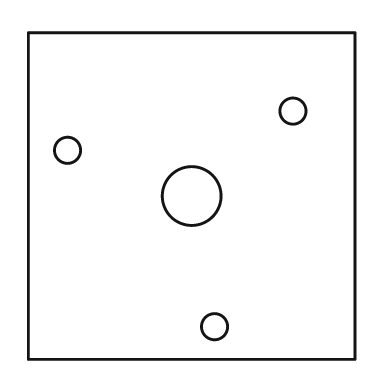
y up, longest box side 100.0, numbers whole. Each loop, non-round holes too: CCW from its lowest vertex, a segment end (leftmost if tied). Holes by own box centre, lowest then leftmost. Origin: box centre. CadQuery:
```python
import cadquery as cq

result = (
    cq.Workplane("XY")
    .moveTo(-50.0, -50.0)
    .lineTo(50.0, -50.0)
    .lineTo(50.0, 50.0)
    .lineTo(-50.0, 50.0)
    .close()
    .moveTo(7.0, -40.0)
    .circle(4.0)
    .moveTo(0.0, 0.0)
    .circle(9.0)
    .moveTo(-38.0, 14.0)
    .circle(4.0)
    .moveTo(31.0, 26.0)
    .circle(4.0)
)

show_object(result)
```